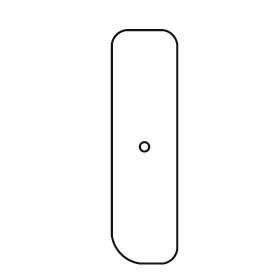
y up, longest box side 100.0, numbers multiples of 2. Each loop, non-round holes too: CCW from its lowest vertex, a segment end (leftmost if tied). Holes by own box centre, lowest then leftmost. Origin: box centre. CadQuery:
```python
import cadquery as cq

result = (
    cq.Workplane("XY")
    .moveTo(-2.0, -50.0)
    .lineTo(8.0, -50.0)
    .threePointArc((12.0, -48.0), (14.0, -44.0))
    .lineTo(14.0, 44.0)
    .threePointArc((12.0, 48.0), (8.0, 50.0))
    .lineTo(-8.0, 50.0)
    .threePointArc((-12.0, 48.0), (-14.0, 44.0))
    .lineTo(-14.0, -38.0)
    .threePointArc((-10.0, -46.0), (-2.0, -50.0))
    .close()
    .moveTo(0.0, 0.0)
    .circle(2.0)
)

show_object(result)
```